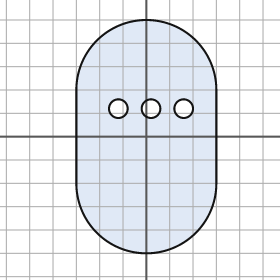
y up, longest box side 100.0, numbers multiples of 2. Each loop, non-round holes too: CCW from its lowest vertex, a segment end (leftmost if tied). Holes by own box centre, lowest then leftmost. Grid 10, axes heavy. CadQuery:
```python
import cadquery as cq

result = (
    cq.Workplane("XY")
    .moveTo(-30.0, -20.0)
    .threePointArc((0.0, -50.0), (30.0, -20.0))
    .lineTo(30.0, 20.0)
    .threePointArc((0.0, 50.0), (-30.0, 20.0))
    .close()
    .moveTo(-12.0, 12.0)
    .circle(4.0)
    .moveTo(2.0, 12.0)
    .circle(4.0)
    .moveTo(16.0, 12.0)
    .circle(4.0)
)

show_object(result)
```